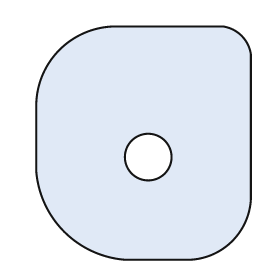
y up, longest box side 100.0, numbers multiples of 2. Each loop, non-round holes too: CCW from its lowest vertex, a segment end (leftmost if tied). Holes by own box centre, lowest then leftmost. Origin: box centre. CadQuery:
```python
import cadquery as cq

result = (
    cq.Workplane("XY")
    .moveTo(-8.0, -50.0)
    .lineTo(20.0, -50.0)
    .threePointArc((38.0, -42.0), (46.0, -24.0))
    .lineTo(46.0, 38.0)
    .threePointArc((42.0, 46.0), (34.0, 50.0))
    .lineTo(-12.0, 50.0)
    .threePointArc((-36.0, 40.0), (-46.0, 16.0))
    .lineTo(-46.0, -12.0)
    .threePointArc((-34.0, -38.0), (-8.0, -50.0))
    .close()
    .moveTo(2.0, -6.0)
    .circle(10.0)
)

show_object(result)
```